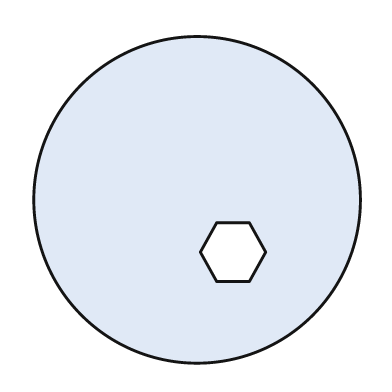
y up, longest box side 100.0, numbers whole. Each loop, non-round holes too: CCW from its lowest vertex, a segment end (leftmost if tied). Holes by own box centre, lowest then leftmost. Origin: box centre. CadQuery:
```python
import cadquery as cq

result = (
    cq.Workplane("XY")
    .moveTo(0.0, 0.0)
    .circle(50.0)
    .moveTo(6.0, -25.0)
    .lineTo(16.0, -25.0)
    .lineTo(21.0, -16.0)
    .lineTo(16.0, -7.0)
    .lineTo(6.0, -7.0)
    .lineTo(1.0, -16.0)
    .close()
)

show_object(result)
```